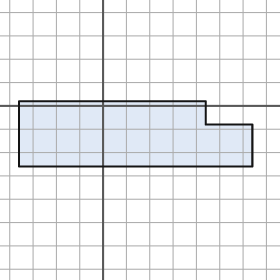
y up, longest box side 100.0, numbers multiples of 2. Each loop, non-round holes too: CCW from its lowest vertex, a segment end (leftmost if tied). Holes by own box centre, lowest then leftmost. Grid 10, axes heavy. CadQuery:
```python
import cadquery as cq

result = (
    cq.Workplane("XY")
    .moveTo(-36.0, -26.0)
    .lineTo(64.0, -26.0)
    .lineTo(64.0, -8.0)
    .lineTo(44.0, -8.0)
    .lineTo(44.0, 2.0)
    .lineTo(-36.0, 2.0)
    .close()
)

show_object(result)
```